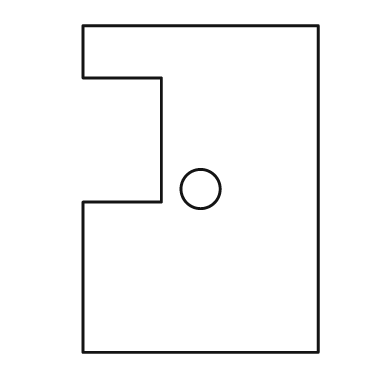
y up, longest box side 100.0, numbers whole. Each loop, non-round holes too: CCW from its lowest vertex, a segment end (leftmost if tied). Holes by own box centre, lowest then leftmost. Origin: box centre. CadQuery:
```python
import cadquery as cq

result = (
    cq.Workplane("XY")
    .moveTo(-36.0, -50.0)
    .lineTo(36.0, -50.0)
    .lineTo(36.0, 50.0)
    .lineTo(-36.0, 50.0)
    .lineTo(-36.0, 34.0)
    .lineTo(-12.0, 34.0)
    .lineTo(-12.0, -4.0)
    .lineTo(-36.0, -4.0)
    .close()
    .moveTo(0.0, 0.0)
    .circle(6.0)
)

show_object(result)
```